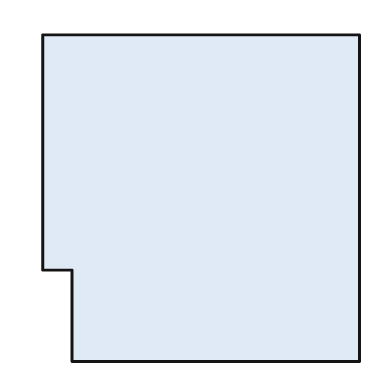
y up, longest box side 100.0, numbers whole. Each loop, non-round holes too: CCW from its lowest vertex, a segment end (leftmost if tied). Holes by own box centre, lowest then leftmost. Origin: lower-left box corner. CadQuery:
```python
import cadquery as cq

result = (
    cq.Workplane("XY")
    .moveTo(9.0, 0.0)
    .lineTo(97.0, 0.0)
    .lineTo(97.0, 100.0)
    .lineTo(0.0, 100.0)
    .lineTo(0.0, 28.0)
    .lineTo(9.0, 28.0)
    .close()
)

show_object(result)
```